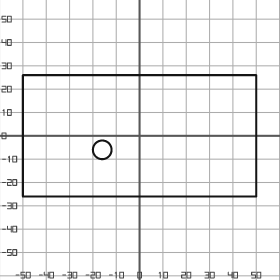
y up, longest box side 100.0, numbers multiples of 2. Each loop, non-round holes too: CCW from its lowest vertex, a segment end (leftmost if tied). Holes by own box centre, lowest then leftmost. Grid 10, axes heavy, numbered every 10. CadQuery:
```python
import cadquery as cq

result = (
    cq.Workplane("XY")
    .moveTo(-50.0, -26.0)
    .lineTo(50.0, -26.0)
    .lineTo(50.0, 26.0)
    .lineTo(-50.0, 26.0)
    .close()
    .moveTo(-16.0, -6.0)
    .circle(4.0)
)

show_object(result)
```